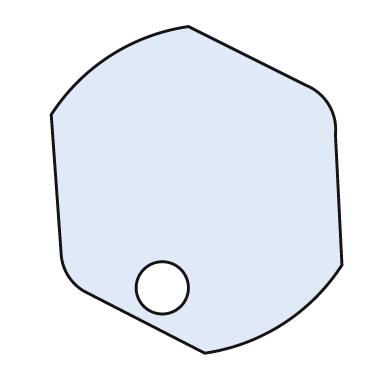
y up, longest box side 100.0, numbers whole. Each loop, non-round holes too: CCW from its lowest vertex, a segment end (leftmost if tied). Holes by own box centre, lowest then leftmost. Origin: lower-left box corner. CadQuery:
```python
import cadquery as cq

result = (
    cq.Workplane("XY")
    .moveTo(47.0, 0.0)
    .threePointArc((71.0, 9.0), (89.0, 27.0))
    .lineTo(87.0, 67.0)
    .threePointArc((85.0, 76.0), (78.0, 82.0))
    .lineTo(42.0, 100.0)
    .threePointArc((18.0, 91.0), (0.0, 73.0))
    .lineTo(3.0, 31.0)
    .threePointArc((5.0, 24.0), (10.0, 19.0))
    .close()
    .moveTo(34.0, 20.0)
    .circle(8.0)
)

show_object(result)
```